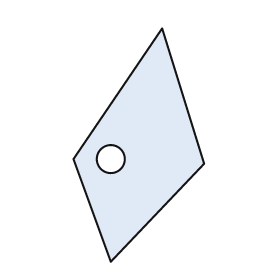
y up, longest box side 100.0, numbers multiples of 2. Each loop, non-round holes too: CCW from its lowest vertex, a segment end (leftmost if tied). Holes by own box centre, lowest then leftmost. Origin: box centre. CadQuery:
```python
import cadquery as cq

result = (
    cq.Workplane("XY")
    .moveTo(-12.0, -50.0)
    .lineTo(28.0, -8.0)
    .lineTo(10.0, 50.0)
    .lineTo(-28.0, -6.0)
    .close()
    .moveTo(-12.0, -6.0)
    .circle(6.0)
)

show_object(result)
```